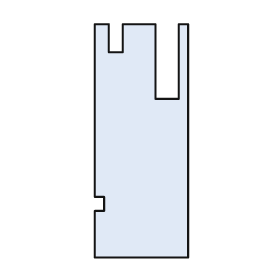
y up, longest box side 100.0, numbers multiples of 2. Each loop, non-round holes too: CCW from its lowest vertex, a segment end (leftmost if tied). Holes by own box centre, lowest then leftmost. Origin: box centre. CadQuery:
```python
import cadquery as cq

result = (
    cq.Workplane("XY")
    .moveTo(-20.0, -50.0)
    .lineTo(20.0, -50.0)
    .lineTo(20.0, 50.0)
    .lineTo(16.0, 50.0)
    .lineTo(16.0, 18.0)
    .lineTo(6.0, 18.0)
    .lineTo(6.0, 50.0)
    .lineTo(-8.0, 50.0)
    .lineTo(-8.0, 38.0)
    .lineTo(-14.0, 38.0)
    .lineTo(-14.0, 50.0)
    .lineTo(-20.0, 50.0)
    .lineTo(-20.0, -24.0)
    .lineTo(-16.0, -24.0)
    .lineTo(-16.0, -30.0)
    .lineTo(-20.0, -30.0)
    .close()
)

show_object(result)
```